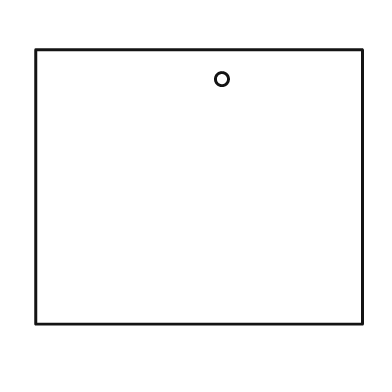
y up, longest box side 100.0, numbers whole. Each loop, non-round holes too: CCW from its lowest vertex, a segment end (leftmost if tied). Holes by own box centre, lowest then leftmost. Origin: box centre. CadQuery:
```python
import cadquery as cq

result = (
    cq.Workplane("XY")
    .moveTo(-50.0, -42.0)
    .lineTo(50.0, -42.0)
    .lineTo(50.0, 42.0)
    .lineTo(-50.0, 42.0)
    .close()
    .moveTo(7.0, 33.0)
    .circle(2.0)
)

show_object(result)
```